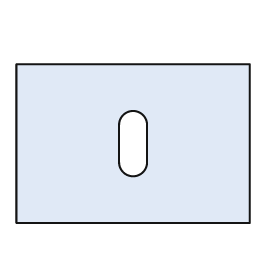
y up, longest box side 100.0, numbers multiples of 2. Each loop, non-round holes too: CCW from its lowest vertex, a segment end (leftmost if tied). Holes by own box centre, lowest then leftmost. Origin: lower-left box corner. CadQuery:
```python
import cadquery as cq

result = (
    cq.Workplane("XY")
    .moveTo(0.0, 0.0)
    .lineTo(100.0, 0.0)
    .lineTo(100.0, 68.0)
    .lineTo(0.0, 68.0)
    .close()
    .moveTo(44.0, 26.0)
    .threePointArc((50.0, 20.0), (56.0, 26.0))
    .lineTo(56.0, 42.0)
    .threePointArc((50.0, 48.0), (44.0, 42.0))
    .close()
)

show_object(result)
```